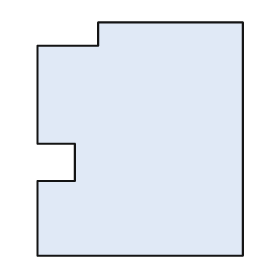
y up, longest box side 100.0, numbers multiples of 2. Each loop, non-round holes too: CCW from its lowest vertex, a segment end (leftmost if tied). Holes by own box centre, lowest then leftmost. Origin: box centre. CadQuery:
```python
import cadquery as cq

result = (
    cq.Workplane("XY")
    .moveTo(-44.0, -50.0)
    .lineTo(44.0, -50.0)
    .lineTo(44.0, 50.0)
    .lineTo(-18.0, 50.0)
    .lineTo(-18.0, 40.0)
    .lineTo(-44.0, 40.0)
    .lineTo(-44.0, -2.0)
    .lineTo(-28.0, -2.0)
    .lineTo(-28.0, -18.0)
    .lineTo(-44.0, -18.0)
    .close()
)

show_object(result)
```